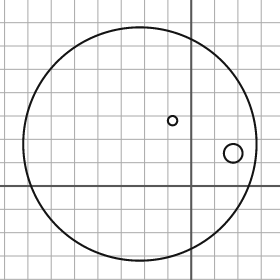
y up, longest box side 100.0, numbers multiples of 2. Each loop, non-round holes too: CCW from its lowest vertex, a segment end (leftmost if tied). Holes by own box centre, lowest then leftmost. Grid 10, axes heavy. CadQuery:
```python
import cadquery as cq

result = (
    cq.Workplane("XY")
    .moveTo(-22.0, 18.0)
    .circle(50.0)
    .moveTo(18.0, 14.0)
    .circle(4.0)
    .moveTo(-8.0, 28.0)
    .circle(2.0)
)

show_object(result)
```